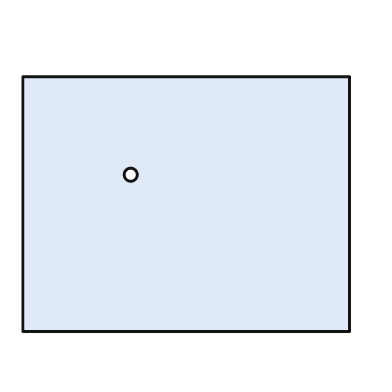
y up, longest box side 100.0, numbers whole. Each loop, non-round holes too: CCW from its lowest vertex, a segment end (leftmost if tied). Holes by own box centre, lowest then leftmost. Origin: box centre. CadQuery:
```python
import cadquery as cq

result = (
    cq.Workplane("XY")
    .moveTo(-50.0, -39.0)
    .lineTo(50.0, -39.0)
    .lineTo(50.0, 39.0)
    .lineTo(-50.0, 39.0)
    .close()
    .moveTo(-17.0, 9.0)
    .circle(2.0)
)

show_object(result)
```